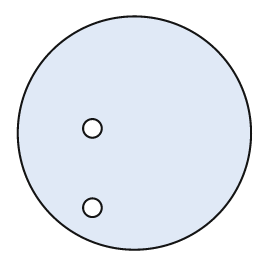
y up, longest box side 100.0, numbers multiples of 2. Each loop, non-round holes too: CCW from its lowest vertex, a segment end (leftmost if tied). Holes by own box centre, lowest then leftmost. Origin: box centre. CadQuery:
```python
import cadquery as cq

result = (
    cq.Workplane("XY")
    .moveTo(0.0, 0.0)
    .circle(50.0)
    .moveTo(-18.0, -32.0)
    .circle(4.0)
    .moveTo(-18.0, 2.0)
    .circle(4.0)
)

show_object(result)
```